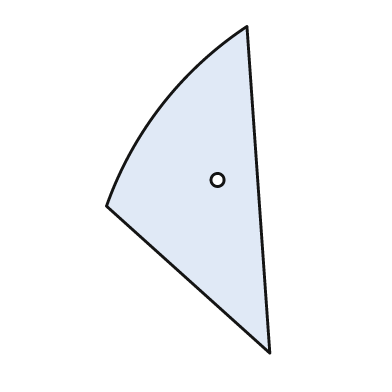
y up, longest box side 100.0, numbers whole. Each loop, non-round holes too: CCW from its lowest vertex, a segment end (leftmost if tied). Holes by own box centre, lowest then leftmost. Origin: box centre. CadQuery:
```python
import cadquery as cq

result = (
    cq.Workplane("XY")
    .moveTo(25.0, -50.0)
    .lineTo(18.0, 50.0)
    .threePointArc((-8.0, 26.0), (-25.0, -5.0))
    .close()
    .moveTo(9.0, 3.0)
    .circle(2.0)
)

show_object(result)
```